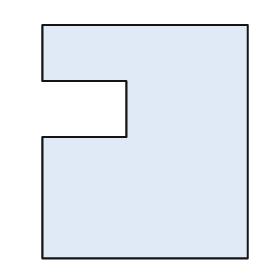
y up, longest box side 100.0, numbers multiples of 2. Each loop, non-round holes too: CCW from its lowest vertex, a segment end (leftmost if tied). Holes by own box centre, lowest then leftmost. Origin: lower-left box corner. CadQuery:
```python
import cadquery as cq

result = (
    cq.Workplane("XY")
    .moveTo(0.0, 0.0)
    .lineTo(88.0, 0.0)
    .lineTo(88.0, 100.0)
    .lineTo(0.0, 100.0)
    .lineTo(0.0, 76.0)
    .lineTo(36.0, 76.0)
    .lineTo(36.0, 52.0)
    .lineTo(0.0, 52.0)
    .close()
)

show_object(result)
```